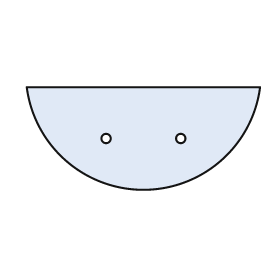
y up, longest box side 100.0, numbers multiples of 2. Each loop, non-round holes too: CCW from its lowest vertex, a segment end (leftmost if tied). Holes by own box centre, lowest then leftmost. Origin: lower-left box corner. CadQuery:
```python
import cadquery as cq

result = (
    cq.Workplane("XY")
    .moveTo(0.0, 44.0)
    .threePointArc((50.0, 0.0), (100.0, 44.0))
    .close()
    .moveTo(34.0, 22.0)
    .circle(2.0)
    .moveTo(66.0, 22.0)
    .circle(2.0)
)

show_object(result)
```